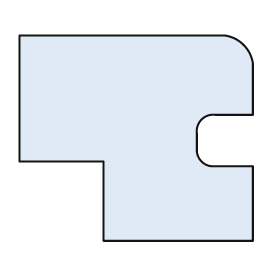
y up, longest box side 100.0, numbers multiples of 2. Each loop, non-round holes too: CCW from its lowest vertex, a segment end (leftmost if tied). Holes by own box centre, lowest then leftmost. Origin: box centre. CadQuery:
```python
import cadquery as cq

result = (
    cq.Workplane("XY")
    .moveTo(-14.0, -44.0)
    .lineTo(50.0, -44.0)
    .lineTo(50.0, -12.0)
    .lineTo(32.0, -12.0)
    .threePointArc((28.0, -10.0), (26.0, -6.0))
    .lineTo(26.0, 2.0)
    .threePointArc((28.0, 8.0), (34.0, 10.0))
    .lineTo(50.0, 10.0)
    .lineTo(50.0, 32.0)
    .threePointArc((46.0, 40.0), (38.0, 44.0))
    .lineTo(-50.0, 44.0)
    .lineTo(-50.0, -10.0)
    .lineTo(-14.0, -10.0)
    .close()
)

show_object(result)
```